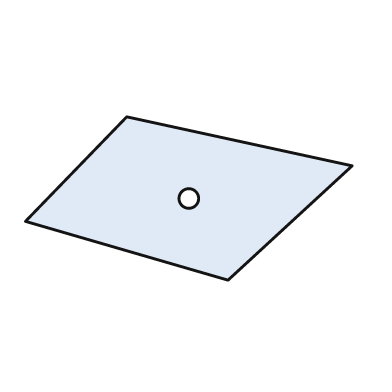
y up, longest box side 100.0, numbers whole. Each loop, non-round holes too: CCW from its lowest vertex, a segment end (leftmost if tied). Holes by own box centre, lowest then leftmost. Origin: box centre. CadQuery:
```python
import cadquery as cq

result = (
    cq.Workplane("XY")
    .moveTo(12.0, -25.0)
    .lineTo(50.0, 10.0)
    .lineTo(-19.0, 25.0)
    .lineTo(-50.0, -7.0)
    .close()
    .moveTo(0.0, 0.0)
    .circle(3.0)
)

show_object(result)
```